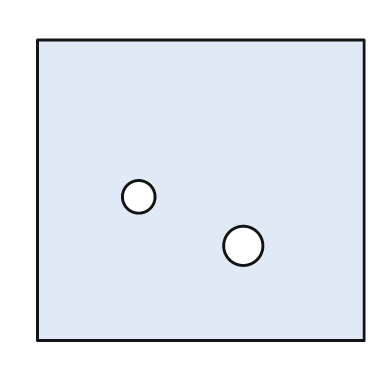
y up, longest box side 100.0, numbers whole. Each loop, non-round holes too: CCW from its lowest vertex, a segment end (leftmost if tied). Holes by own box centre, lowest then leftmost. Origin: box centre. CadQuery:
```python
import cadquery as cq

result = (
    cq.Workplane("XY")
    .moveTo(-50.0, -46.0)
    .lineTo(50.0, -46.0)
    .lineTo(50.0, 46.0)
    .lineTo(-50.0, 46.0)
    .close()
    .moveTo(13.0, -17.0)
    .circle(6.0)
    .moveTo(-19.0, -2.0)
    .circle(5.0)
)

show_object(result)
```